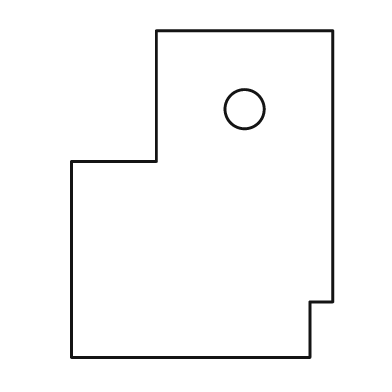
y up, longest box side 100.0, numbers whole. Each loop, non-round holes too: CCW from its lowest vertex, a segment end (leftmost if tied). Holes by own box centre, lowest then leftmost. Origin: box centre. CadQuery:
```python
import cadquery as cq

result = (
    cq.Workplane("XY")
    .moveTo(-40.0, -50.0)
    .lineTo(33.0, -50.0)
    .lineTo(33.0, -33.0)
    .lineTo(40.0, -33.0)
    .lineTo(40.0, 50.0)
    .lineTo(-14.0, 50.0)
    .lineTo(-14.0, 10.0)
    .lineTo(-40.0, 10.0)
    .close()
    .moveTo(13.0, 26.0)
    .circle(6.0)
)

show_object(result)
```